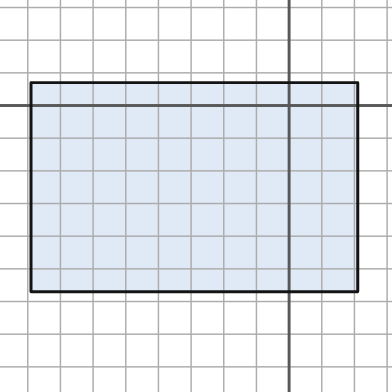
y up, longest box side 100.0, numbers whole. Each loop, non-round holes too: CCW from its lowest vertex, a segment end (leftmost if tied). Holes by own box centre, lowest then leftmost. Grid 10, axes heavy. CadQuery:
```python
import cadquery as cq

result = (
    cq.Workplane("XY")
    .moveTo(-79.0, -57.0)
    .lineTo(21.0, -57.0)
    .lineTo(21.0, 7.0)
    .lineTo(-79.0, 7.0)
    .close()
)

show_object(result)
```